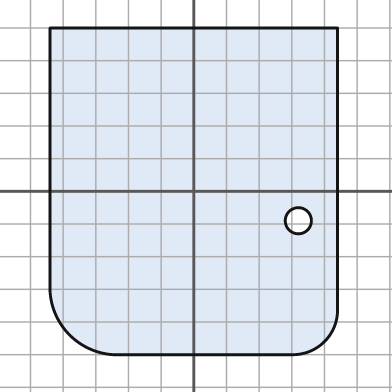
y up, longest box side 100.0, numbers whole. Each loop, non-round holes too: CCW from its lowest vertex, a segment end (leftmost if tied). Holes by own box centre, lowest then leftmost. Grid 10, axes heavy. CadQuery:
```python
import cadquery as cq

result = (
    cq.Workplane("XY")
    .moveTo(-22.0, -50.0)
    .lineTo(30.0, -50.0)
    .threePointArc((40.0, -46.0), (44.0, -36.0))
    .lineTo(44.0, 50.0)
    .lineTo(-44.0, 50.0)
    .lineTo(-44.0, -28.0)
    .threePointArc((-38.0, -44.0), (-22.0, -50.0))
    .close()
    .moveTo(32.0, -9.0)
    .circle(4.0)
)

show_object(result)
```